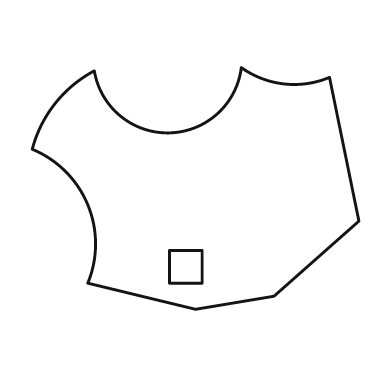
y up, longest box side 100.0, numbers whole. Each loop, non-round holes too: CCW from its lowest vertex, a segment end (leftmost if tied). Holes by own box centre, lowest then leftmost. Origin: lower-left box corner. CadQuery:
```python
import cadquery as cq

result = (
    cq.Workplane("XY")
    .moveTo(50.0, 0.0)
    .lineTo(74.0, 4.0)
    .lineTo(100.0, 27.0)
    .lineTo(91.0, 71.0)
    .threePointArc((77.0, 69.0), (64.0, 74.0))
    .threePointArc((42.0, 54.0), (19.0, 73.0))
    .threePointArc((7.0, 63.0), (0.0, 49.0))
    .threePointArc((17.0, 32.0), (17.0, 8.0))
    .close()
    .moveTo(42.0, 8.0)
    .lineTo(52.0, 8.0)
    .lineTo(52.0, 18.0)
    .lineTo(42.0, 18.0)
    .close()
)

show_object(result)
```